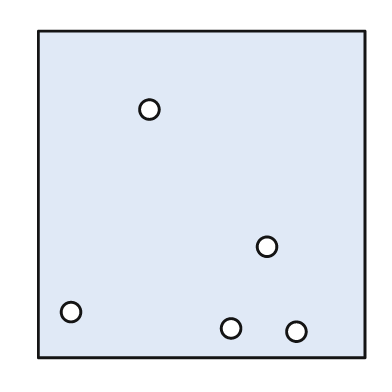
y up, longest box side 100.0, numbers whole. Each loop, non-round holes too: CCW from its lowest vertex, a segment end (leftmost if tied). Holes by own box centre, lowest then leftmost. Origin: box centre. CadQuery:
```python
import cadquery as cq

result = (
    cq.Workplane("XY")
    .moveTo(-50.0, -50.0)
    .lineTo(50.0, -50.0)
    .lineTo(50.0, 50.0)
    .lineTo(-50.0, 50.0)
    .close()
    .moveTo(29.0, -42.0)
    .circle(3.0)
    .moveTo(9.0, -41.0)
    .circle(3.0)
    .moveTo(-40.0, -36.0)
    .circle(3.0)
    .moveTo(20.0, -16.0)
    .circle(3.0)
    .moveTo(-16.0, 26.0)
    .circle(3.0)
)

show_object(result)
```